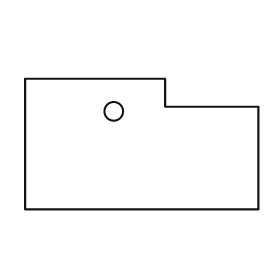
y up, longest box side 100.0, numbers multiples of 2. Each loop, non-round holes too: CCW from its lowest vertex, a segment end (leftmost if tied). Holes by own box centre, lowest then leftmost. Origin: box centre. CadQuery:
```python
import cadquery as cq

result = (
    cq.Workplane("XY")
    .moveTo(-50.0, -28.0)
    .lineTo(50.0, -28.0)
    .lineTo(50.0, 16.0)
    .lineTo(10.0, 16.0)
    .lineTo(10.0, 28.0)
    .lineTo(-50.0, 28.0)
    .close()
    .moveTo(-12.0, 14.0)
    .circle(4.0)
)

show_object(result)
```